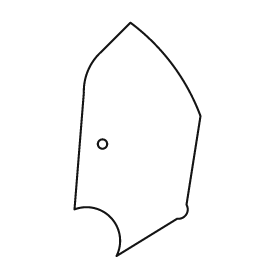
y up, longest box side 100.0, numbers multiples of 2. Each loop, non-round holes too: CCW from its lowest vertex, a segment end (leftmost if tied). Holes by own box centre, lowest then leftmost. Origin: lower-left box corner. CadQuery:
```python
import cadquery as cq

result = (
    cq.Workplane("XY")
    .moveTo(18.0, 0.0)
    .lineTo(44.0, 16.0)
    .threePointArc((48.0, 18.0), (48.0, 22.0))
    .lineTo(54.0, 60.0)
    .threePointArc((42.0, 82.0), (24.0, 100.0))
    .lineTo(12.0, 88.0)
    .threePointArc((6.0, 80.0), (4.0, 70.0))
    .lineTo(0.0, 20.0)
    .threePointArc((16.0, 16.0), (18.0, 0.0))
    .close()
    .moveTo(12.0, 48.0)
    .circle(2.0)
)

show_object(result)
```